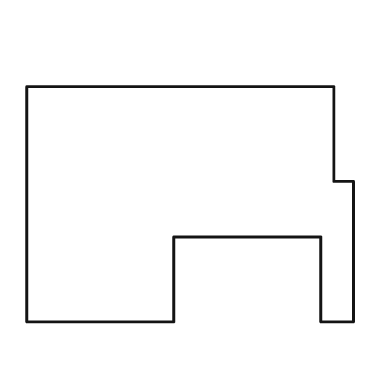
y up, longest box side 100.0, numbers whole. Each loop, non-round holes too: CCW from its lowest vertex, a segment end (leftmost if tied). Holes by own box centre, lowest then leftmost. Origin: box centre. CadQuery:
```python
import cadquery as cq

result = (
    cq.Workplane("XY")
    .moveTo(-50.0, -36.0)
    .lineTo(-5.0, -36.0)
    .lineTo(-5.0, -10.0)
    .lineTo(40.0, -10.0)
    .lineTo(40.0, -36.0)
    .lineTo(50.0, -36.0)
    .lineTo(50.0, 7.0)
    .lineTo(44.0, 7.0)
    .lineTo(44.0, 36.0)
    .lineTo(-50.0, 36.0)
    .close()
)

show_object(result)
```